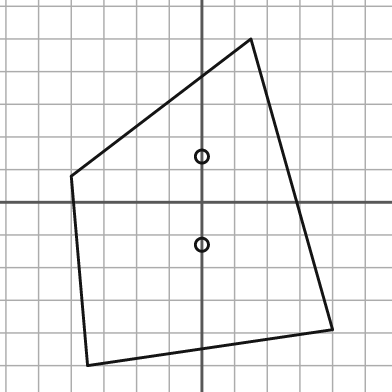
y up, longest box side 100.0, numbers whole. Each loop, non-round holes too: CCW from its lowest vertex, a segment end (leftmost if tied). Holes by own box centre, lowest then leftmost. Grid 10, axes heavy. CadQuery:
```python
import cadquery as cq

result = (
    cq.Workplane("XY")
    .moveTo(-35.0, -50.0)
    .lineTo(40.0, -39.0)
    .lineTo(15.0, 50.0)
    .lineTo(-40.0, 8.0)
    .close()
    .moveTo(0.0, -13.0)
    .circle(2.0)
    .moveTo(0.0, 14.0)
    .circle(2.0)
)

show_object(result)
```